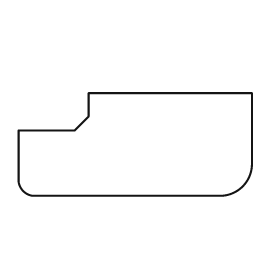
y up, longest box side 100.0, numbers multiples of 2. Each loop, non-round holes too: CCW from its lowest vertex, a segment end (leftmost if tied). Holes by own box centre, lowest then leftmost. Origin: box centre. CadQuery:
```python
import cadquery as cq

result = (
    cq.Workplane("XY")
    .moveTo(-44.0, -22.0)
    .lineTo(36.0, -22.0)
    .threePointArc((46.0, -18.0), (50.0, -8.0))
    .lineTo(50.0, 22.0)
    .lineTo(-20.0, 22.0)
    .lineTo(-20.0, 12.0)
    .lineTo(-26.0, 6.0)
    .lineTo(-50.0, 6.0)
    .lineTo(-50.0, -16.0)
    .threePointArc((-48.0, -20.0), (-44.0, -22.0))
    .close()
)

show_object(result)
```